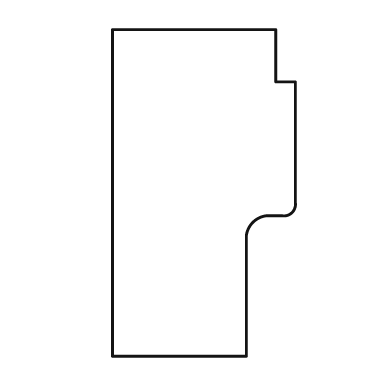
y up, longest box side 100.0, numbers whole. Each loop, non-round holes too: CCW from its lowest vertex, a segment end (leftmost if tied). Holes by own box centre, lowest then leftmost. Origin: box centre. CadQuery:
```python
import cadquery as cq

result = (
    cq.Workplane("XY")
    .moveTo(-28.0, -50.0)
    .lineTo(13.0, -50.0)
    .lineTo(13.0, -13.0)
    .threePointArc((15.0, -9.0), (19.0, -7.0))
    .lineTo(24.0, -7.0)
    .threePointArc((27.0, -6.0), (28.0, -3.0))
    .lineTo(28.0, 34.0)
    .lineTo(22.0, 34.0)
    .lineTo(22.0, 50.0)
    .lineTo(-28.0, 50.0)
    .close()
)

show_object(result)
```